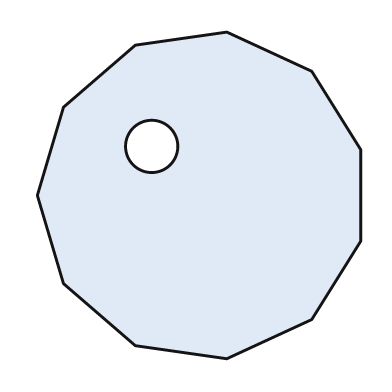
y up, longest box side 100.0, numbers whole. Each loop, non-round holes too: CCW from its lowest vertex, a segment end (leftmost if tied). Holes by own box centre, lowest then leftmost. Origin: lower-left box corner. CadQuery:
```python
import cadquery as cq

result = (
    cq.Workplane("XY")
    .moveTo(58.0, 0.0)
    .lineTo(84.0, 12.0)
    .lineTo(99.0, 36.0)
    .lineTo(99.0, 64.0)
    .lineTo(84.0, 88.0)
    .lineTo(58.0, 100.0)
    .lineTo(30.0, 96.0)
    .lineTo(8.0, 77.0)
    .lineTo(0.0, 50.0)
    .lineTo(8.0, 23.0)
    .lineTo(30.0, 4.0)
    .close()
    .moveTo(35.0, 65.0)
    .circle(8.0)
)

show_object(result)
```